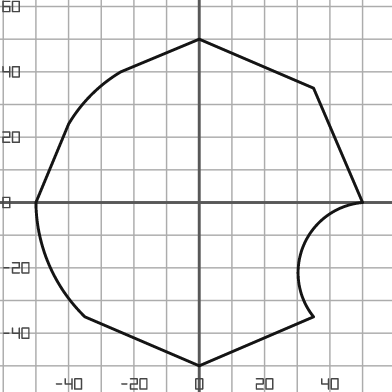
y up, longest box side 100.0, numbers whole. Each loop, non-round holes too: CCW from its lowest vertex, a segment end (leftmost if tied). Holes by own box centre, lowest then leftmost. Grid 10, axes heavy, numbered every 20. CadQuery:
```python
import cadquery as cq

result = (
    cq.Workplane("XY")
    .moveTo(0.0, -50.0)
    .lineTo(35.0, -35.0)
    .threePointArc((32.0, -13.0), (50.0, 0.0))
    .lineTo(35.0, 35.0)
    .lineTo(0.0, 50.0)
    .lineTo(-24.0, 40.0)
    .threePointArc((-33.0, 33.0), (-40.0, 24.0))
    .lineTo(-50.0, 0.0)
    .threePointArc((-46.0, -19.0), (-35.0, -35.0))
    .close()
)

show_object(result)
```